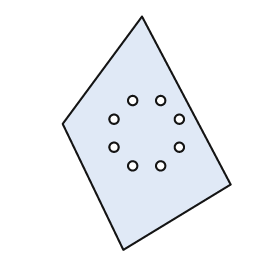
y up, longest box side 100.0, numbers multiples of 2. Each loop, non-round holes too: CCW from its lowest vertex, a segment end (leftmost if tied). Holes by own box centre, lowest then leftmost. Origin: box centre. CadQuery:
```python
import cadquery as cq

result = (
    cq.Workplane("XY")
    .moveTo(-10.0, -50.0)
    .lineTo(36.0, -22.0)
    .lineTo(-2.0, 50.0)
    .lineTo(-36.0, 4.0)
    .close()
    .moveTo(-6.0, -14.0)
    .circle(2.0)
    .moveTo(6.0, -14.0)
    .circle(2.0)
    .moveTo(-14.0, -6.0)
    .circle(2.0)
    .moveTo(14.0, -6.0)
    .circle(2.0)
    .moveTo(-14.0, 6.0)
    .circle(2.0)
    .moveTo(14.0, 6.0)
    .circle(2.0)
    .moveTo(-6.0, 14.0)
    .circle(2.0)
    .moveTo(6.0, 14.0)
    .circle(2.0)
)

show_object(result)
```